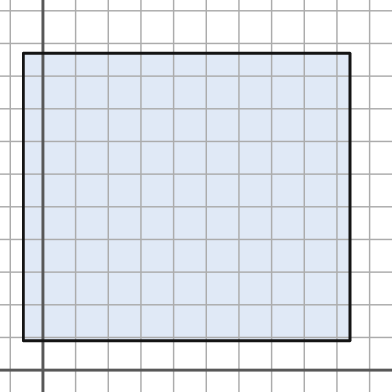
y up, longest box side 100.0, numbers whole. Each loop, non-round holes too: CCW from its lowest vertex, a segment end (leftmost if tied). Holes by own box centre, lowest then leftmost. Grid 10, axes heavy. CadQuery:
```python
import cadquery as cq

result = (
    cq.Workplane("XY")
    .moveTo(-6.0, 9.0)
    .lineTo(94.0, 9.0)
    .lineTo(94.0, 97.0)
    .lineTo(-6.0, 97.0)
    .close()
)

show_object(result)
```